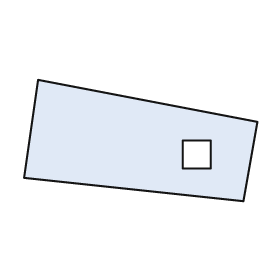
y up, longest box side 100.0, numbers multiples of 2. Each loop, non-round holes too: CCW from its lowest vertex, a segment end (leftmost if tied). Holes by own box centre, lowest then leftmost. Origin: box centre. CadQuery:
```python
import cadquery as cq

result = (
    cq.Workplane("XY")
    .moveTo(44.0, -26.0)
    .lineTo(50.0, 8.0)
    .lineTo(-44.0, 26.0)
    .lineTo(-50.0, -16.0)
    .close()
    .moveTo(18.0, -12.0)
    .lineTo(30.0, -12.0)
    .lineTo(30.0, 0.0)
    .lineTo(18.0, 0.0)
    .close()
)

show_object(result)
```